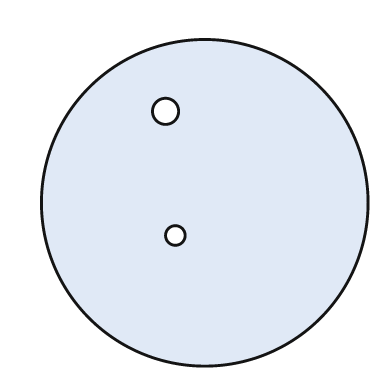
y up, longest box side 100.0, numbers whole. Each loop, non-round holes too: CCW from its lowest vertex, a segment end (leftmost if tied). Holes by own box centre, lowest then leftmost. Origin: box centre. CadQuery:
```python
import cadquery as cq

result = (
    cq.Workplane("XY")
    .moveTo(0.0, 0.0)
    .circle(50.0)
    .moveTo(-9.0, -10.0)
    .circle(3.0)
    .moveTo(-12.0, 28.0)
    .circle(4.0)
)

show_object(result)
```